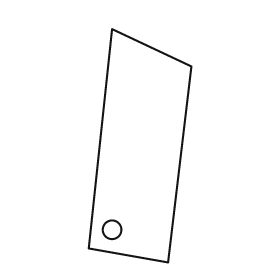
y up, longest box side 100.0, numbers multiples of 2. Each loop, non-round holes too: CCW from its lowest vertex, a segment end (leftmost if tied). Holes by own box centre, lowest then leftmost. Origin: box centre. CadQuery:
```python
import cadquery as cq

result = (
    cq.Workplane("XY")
    .moveTo(12.0, -50.0)
    .lineTo(22.0, 34.0)
    .lineTo(-12.0, 50.0)
    .lineTo(-22.0, -44.0)
    .close()
    .moveTo(-12.0, -36.0)
    .circle(4.0)
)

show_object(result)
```